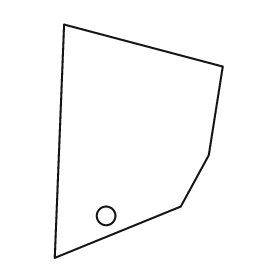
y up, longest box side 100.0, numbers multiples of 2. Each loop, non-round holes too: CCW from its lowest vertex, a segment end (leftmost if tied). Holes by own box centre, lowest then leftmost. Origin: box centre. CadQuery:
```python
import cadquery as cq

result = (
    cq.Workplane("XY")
    .moveTo(-36.0, -50.0)
    .lineTo(18.0, -28.0)
    .lineTo(30.0, -6.0)
    .lineTo(36.0, 32.0)
    .lineTo(-32.0, 50.0)
    .close()
    .moveTo(-14.0, -32.0)
    .circle(4.0)
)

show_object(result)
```